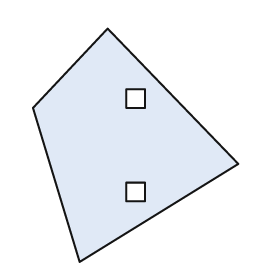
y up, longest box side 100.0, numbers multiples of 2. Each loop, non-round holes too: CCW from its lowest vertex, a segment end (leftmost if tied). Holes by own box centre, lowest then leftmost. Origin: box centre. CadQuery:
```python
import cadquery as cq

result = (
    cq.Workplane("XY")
    .moveTo(-24.0, -50.0)
    .lineTo(44.0, -8.0)
    .lineTo(-12.0, 50.0)
    .lineTo(-44.0, 16.0)
    .close()
    .moveTo(-4.0, -24.0)
    .lineTo(4.0, -24.0)
    .lineTo(4.0, -16.0)
    .lineTo(-4.0, -16.0)
    .close()
    .moveTo(-4.0, 16.0)
    .lineTo(4.0, 16.0)
    .lineTo(4.0, 24.0)
    .lineTo(-4.0, 24.0)
    .close()
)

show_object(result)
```